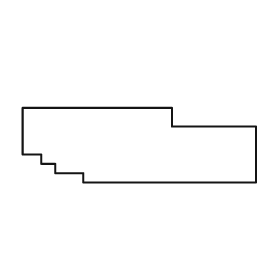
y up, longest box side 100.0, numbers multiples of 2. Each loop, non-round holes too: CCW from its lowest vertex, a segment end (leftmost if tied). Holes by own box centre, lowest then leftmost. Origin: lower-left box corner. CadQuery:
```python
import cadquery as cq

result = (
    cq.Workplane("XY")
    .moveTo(26.0, 0.0)
    .lineTo(100.0, 0.0)
    .lineTo(100.0, 24.0)
    .lineTo(64.0, 24.0)
    .lineTo(64.0, 32.0)
    .lineTo(0.0, 32.0)
    .lineTo(0.0, 12.0)
    .lineTo(8.0, 12.0)
    .lineTo(8.0, 8.0)
    .lineTo(14.0, 8.0)
    .lineTo(14.0, 4.0)
    .lineTo(26.0, 4.0)
    .close()
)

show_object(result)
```